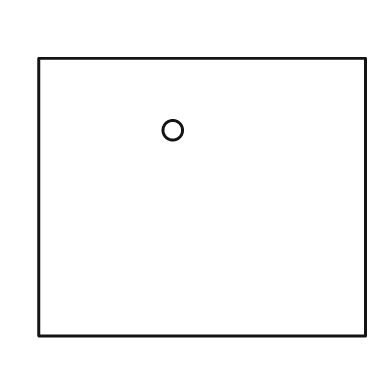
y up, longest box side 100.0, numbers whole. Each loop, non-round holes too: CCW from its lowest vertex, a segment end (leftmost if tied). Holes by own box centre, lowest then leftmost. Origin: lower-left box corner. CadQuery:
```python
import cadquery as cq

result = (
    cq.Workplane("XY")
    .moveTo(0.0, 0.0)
    .lineTo(100.0, 0.0)
    .lineTo(100.0, 85.0)
    .lineTo(0.0, 85.0)
    .close()
    .moveTo(41.0, 63.0)
    .circle(3.0)
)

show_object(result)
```